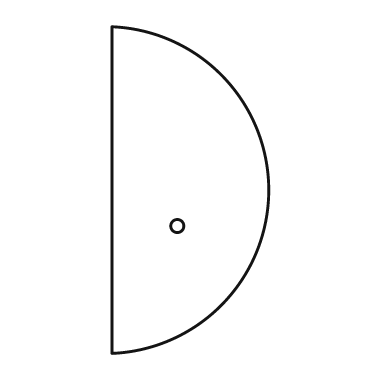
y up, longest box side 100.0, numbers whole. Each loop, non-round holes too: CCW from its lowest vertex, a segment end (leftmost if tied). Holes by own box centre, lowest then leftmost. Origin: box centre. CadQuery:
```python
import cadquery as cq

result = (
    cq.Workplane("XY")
    .moveTo(-24.0, -50.0)
    .threePointArc((24.0, 0.0), (-24.0, 50.0))
    .close()
    .moveTo(-4.0, -11.0)
    .circle(2.0)
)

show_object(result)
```